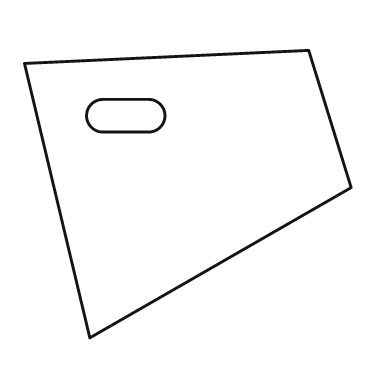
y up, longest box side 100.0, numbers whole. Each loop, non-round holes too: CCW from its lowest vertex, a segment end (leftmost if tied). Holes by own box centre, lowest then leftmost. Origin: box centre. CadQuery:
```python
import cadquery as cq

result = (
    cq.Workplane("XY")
    .moveTo(-30.0, -44.0)
    .lineTo(50.0, 2.0)
    .lineTo(37.0, 44.0)
    .lineTo(-50.0, 40.0)
    .close()
    .moveTo(-26.0, 19.0)
    .lineTo(-12.0, 19.0)
    .threePointArc((-7.0, 24.0), (-12.0, 29.0))
    .lineTo(-26.0, 29.0)
    .threePointArc((-31.0, 24.0), (-26.0, 19.0))
    .close()
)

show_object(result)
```